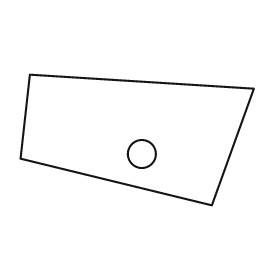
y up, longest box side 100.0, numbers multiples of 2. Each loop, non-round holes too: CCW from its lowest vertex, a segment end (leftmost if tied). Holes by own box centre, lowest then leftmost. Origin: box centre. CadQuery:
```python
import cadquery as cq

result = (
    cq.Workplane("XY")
    .moveTo(32.0, -28.0)
    .lineTo(50.0, 22.0)
    .lineTo(-46.0, 28.0)
    .lineTo(-50.0, -8.0)
    .close()
    .moveTo(2.0, -6.0)
    .circle(6.0)
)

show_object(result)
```